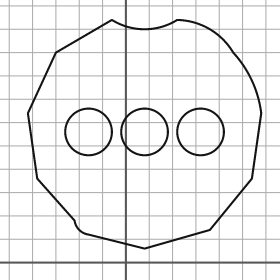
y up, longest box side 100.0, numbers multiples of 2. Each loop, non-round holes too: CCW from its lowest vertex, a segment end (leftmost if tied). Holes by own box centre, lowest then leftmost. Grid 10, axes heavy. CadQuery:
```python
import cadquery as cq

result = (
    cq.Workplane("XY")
    .moveTo(8.0, 6.0)
    .lineTo(36.0, 14.0)
    .lineTo(54.0, 36.0)
    .lineTo(58.0, 64.0)
    .threePointArc((54.0, 78.0), (46.0, 90.0))
    .threePointArc((36.0, 100.0), (22.0, 104.0))
    .threePointArc((8.0, 100.0), (-6.0, 104.0))
    .lineTo(-30.0, 90.0)
    .lineTo(-42.0, 64.0)
    .lineTo(-38.0, 36.0)
    .lineTo(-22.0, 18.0)
    .threePointArc((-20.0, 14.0), (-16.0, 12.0))
    .close()
    .moveTo(-16.0, 56.0)
    .circle(10.0)
    .moveTo(8.0, 56.0)
    .circle(10.0)
    .moveTo(32.0, 56.0)
    .circle(10.0)
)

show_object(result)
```